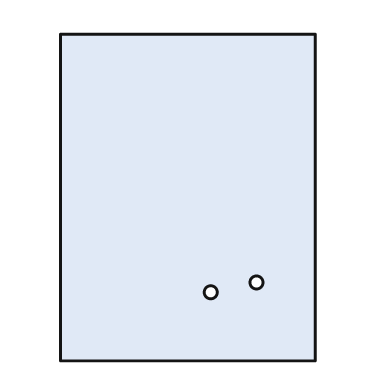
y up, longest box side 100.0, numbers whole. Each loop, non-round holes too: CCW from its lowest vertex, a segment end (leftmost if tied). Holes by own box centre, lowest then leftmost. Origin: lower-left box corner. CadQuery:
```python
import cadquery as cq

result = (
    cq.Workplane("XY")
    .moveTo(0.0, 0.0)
    .lineTo(78.0, 0.0)
    .lineTo(78.0, 100.0)
    .lineTo(0.0, 100.0)
    .close()
    .moveTo(46.0, 21.0)
    .circle(2.0)
    .moveTo(60.0, 24.0)
    .circle(2.0)
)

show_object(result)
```